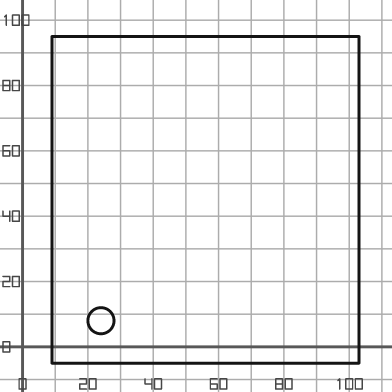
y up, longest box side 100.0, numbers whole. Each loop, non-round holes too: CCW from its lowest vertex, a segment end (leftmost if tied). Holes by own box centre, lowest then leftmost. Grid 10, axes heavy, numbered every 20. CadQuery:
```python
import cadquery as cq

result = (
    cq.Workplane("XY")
    .moveTo(9.0, -5.0)
    .lineTo(103.0, -5.0)
    .lineTo(103.0, 95.0)
    .lineTo(9.0, 95.0)
    .close()
    .moveTo(24.0, 8.0)
    .circle(4.0)
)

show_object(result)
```